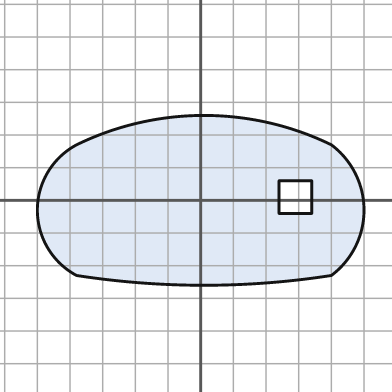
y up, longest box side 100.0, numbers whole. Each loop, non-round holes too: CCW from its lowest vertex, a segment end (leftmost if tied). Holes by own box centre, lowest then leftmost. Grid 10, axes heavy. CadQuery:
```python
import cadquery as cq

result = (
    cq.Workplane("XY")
    .moveTo(-38.0, -23.0)
    .threePointArc((1.0, -26.0), (40.0, -23.0))
    .threePointArc((50.0, -3.0), (40.0, 17.0))
    .threePointArc((1.0, 26.0), (-38.0, 17.0))
    .threePointArc((-50.0, -3.0), (-38.0, -23.0))
    .close()
    .moveTo(24.0, -4.0)
    .lineTo(34.0, -4.0)
    .lineTo(34.0, 6.0)
    .lineTo(24.0, 6.0)
    .close()
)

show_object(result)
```